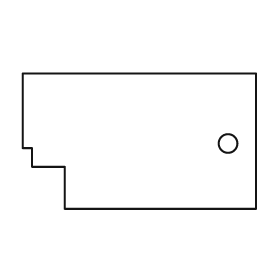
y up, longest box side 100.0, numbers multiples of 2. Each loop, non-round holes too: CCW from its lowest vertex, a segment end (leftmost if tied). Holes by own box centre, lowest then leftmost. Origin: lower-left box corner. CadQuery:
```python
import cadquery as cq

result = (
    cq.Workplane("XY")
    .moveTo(18.0, 0.0)
    .lineTo(100.0, 0.0)
    .lineTo(100.0, 58.0)
    .lineTo(0.0, 58.0)
    .lineTo(0.0, 26.0)
    .lineTo(4.0, 26.0)
    .lineTo(4.0, 18.0)
    .lineTo(18.0, 18.0)
    .close()
    .moveTo(88.0, 28.0)
    .circle(4.0)
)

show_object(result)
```